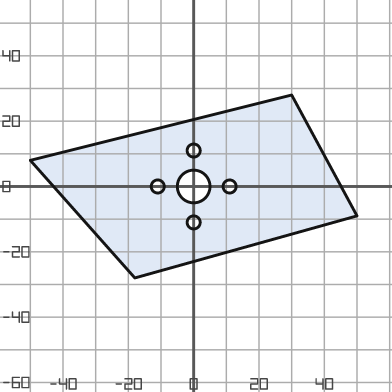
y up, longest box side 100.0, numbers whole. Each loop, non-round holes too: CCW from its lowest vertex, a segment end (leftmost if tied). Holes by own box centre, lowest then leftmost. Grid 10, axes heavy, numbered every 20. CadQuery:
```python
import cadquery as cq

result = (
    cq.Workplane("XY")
    .moveTo(-18.0, -28.0)
    .lineTo(50.0, -9.0)
    .lineTo(30.0, 28.0)
    .lineTo(-50.0, 8.0)
    .close()
    .moveTo(0.0, -11.0)
    .circle(2.0)
    .moveTo(-11.0, 0.0)
    .circle(2.0)
    .moveTo(0.0, 0.0)
    .circle(5.0)
    .moveTo(11.0, 0.0)
    .circle(2.0)
    .moveTo(0.0, 11.0)
    .circle(2.0)
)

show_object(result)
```